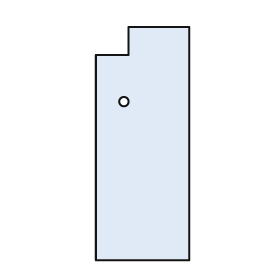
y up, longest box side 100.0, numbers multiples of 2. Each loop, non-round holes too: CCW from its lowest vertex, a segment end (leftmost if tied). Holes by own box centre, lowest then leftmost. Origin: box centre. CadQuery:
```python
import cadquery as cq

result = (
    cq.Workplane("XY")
    .moveTo(-20.0, -50.0)
    .lineTo(20.0, -50.0)
    .lineTo(20.0, 50.0)
    .lineTo(-6.0, 50.0)
    .lineTo(-6.0, 38.0)
    .lineTo(-20.0, 38.0)
    .close()
    .moveTo(-8.0, 18.0)
    .circle(2.0)
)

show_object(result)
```